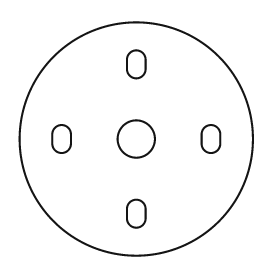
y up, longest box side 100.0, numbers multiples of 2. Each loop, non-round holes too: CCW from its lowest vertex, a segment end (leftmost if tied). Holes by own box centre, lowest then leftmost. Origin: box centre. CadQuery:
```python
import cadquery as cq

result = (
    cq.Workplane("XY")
    .moveTo(0.0, 0.0)
    .circle(50.0)
    .moveTo(-4.0, -34.0)
    .threePointArc((0.0, -38.0), (4.0, -34.0))
    .lineTo(4.0, -30.0)
    .threePointArc((0.0, -26.0), (-4.0, -30.0))
    .close()
    .moveTo(-36.0, -2.0)
    .threePointArc((-32.0, -6.0), (-28.0, -2.0))
    .lineTo(-28.0, 2.0)
    .threePointArc((-32.0, 6.0), (-36.0, 2.0))
    .close()
    .moveTo(0.0, 0.0)
    .circle(8.0)
    .moveTo(28.0, -2.0)
    .threePointArc((32.0, -6.0), (36.0, -2.0))
    .lineTo(36.0, 2.0)
    .threePointArc((32.0, 6.0), (28.0, 2.0))
    .close()
    .moveTo(-4.0, 30.0)
    .threePointArc((0.0, 26.0), (4.0, 30.0))
    .lineTo(4.0, 34.0)
    .threePointArc((0.0, 38.0), (-4.0, 34.0))
    .close()
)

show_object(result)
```